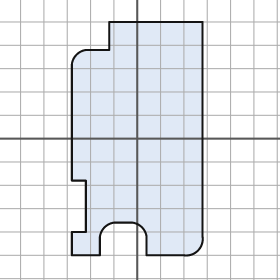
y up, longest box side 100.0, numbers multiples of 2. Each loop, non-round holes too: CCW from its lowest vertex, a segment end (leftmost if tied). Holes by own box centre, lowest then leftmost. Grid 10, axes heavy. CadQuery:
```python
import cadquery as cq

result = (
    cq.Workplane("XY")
    .moveTo(-28.0, -50.0)
    .lineTo(-16.0, -50.0)
    .lineTo(-16.0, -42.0)
    .threePointArc((-14.0, -38.0), (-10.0, -36.0))
    .lineTo(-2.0, -36.0)
    .threePointArc((2.0, -38.0), (4.0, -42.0))
    .lineTo(4.0, -50.0)
    .lineTo(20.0, -50.0)
    .threePointArc((26.0, -48.0), (28.0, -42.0))
    .lineTo(28.0, 50.0)
    .lineTo(-12.0, 50.0)
    .lineTo(-12.0, 38.0)
    .lineTo(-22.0, 38.0)
    .threePointArc((-26.0, 36.0), (-28.0, 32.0))
    .lineTo(-28.0, -18.0)
    .lineTo(-22.0, -18.0)
    .lineTo(-22.0, -40.0)
    .lineTo(-28.0, -40.0)
    .close()
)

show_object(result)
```